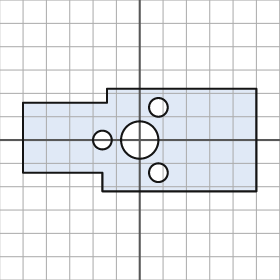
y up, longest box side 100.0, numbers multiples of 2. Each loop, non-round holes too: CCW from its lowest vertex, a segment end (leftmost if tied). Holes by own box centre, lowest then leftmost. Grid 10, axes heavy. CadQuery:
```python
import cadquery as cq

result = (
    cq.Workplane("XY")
    .moveTo(-16.0, -22.0)
    .lineTo(50.0, -22.0)
    .lineTo(50.0, 22.0)
    .lineTo(-14.0, 22.0)
    .lineTo(-14.0, 16.0)
    .lineTo(-50.0, 16.0)
    .lineTo(-50.0, -14.0)
    .lineTo(-16.0, -14.0)
    .close()
    .moveTo(8.0, -14.0)
    .circle(4.0)
    .moveTo(-16.0, 0.0)
    .circle(4.0)
    .moveTo(0.0, 0.0)
    .circle(8.0)
    .moveTo(8.0, 14.0)
    .circle(4.0)
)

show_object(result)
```